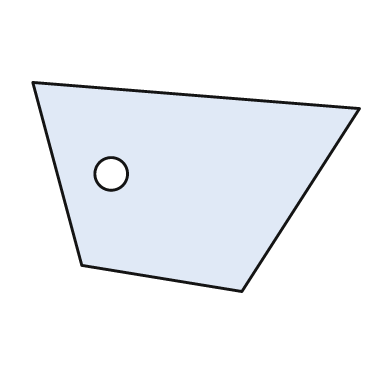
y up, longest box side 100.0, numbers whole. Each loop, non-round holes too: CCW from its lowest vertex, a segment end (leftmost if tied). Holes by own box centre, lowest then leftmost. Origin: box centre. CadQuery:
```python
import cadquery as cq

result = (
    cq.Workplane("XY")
    .moveTo(14.0, -32.0)
    .lineTo(50.0, 24.0)
    .lineTo(-50.0, 32.0)
    .lineTo(-35.0, -24.0)
    .close()
    .moveTo(-26.0, 4.0)
    .circle(5.0)
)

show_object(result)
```